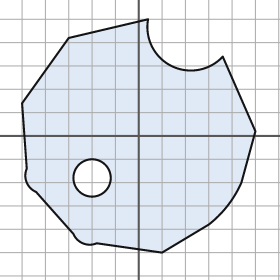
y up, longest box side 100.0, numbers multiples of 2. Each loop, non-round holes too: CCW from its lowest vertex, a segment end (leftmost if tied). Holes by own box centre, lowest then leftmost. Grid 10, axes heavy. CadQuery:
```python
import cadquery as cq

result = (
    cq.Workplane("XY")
    .moveTo(10.0, -50.0)
    .lineTo(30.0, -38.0)
    .threePointArc((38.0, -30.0), (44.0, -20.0))
    .lineTo(50.0, 2.0)
    .lineTo(36.0, 34.0)
    .threePointArc((14.0, 30.0), (4.0, 50.0))
    .lineTo(-30.0, 42.0)
    .lineTo(-50.0, 14.0)
    .lineTo(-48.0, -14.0)
    .threePointArc((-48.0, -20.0), (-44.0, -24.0))
    .lineTo(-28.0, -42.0)
    .threePointArc((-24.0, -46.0), (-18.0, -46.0))
    .close()
    .moveTo(-20.0, -18.0)
    .circle(8.0)
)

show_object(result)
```